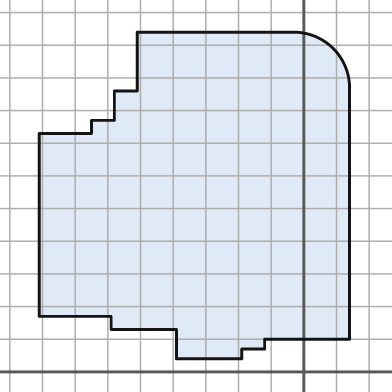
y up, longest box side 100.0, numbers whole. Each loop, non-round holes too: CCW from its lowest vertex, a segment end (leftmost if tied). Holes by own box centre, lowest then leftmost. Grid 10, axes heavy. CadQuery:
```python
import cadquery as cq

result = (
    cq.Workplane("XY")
    .moveTo(-39.0, 4.0)
    .lineTo(-19.0, 4.0)
    .lineTo(-19.0, 7.0)
    .lineTo(-12.0, 7.0)
    .lineTo(-12.0, 10.0)
    .lineTo(14.0, 10.0)
    .lineTo(14.0, 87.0)
    .threePointArc((9.0, 99.0), (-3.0, 104.0))
    .lineTo(-51.0, 104.0)
    .lineTo(-51.0, 86.0)
    .lineTo(-58.0, 86.0)
    .lineTo(-58.0, 77.0)
    .lineTo(-65.0, 77.0)
    .lineTo(-65.0, 73.0)
    .lineTo(-81.0, 73.0)
    .lineTo(-81.0, 17.0)
    .lineTo(-59.0, 17.0)
    .lineTo(-59.0, 13.0)
    .lineTo(-39.0, 13.0)
    .close()
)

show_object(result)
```